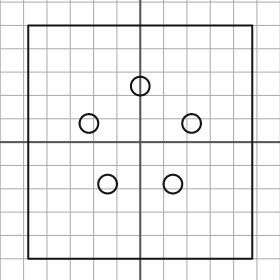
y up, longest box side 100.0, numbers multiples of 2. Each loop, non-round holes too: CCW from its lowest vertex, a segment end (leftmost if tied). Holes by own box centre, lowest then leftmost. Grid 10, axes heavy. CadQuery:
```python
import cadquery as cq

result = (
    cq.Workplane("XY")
    .moveTo(-48.0, -50.0)
    .lineTo(48.0, -50.0)
    .lineTo(48.0, 50.0)
    .lineTo(-48.0, 50.0)
    .close()
    .moveTo(-14.0, -18.0)
    .circle(4.0)
    .moveTo(14.0, -18.0)
    .circle(4.0)
    .moveTo(-22.0, 8.0)
    .circle(4.0)
    .moveTo(22.0, 8.0)
    .circle(4.0)
    .moveTo(0.0, 24.0)
    .circle(4.0)
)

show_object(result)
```